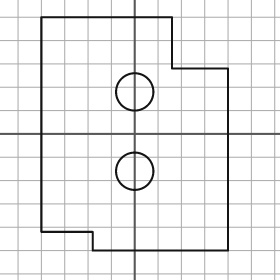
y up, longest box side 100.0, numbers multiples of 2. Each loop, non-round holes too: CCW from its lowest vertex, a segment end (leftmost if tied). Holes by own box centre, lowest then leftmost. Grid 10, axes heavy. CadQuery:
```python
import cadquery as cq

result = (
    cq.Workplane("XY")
    .moveTo(-18.0, -50.0)
    .lineTo(40.0, -50.0)
    .lineTo(40.0, 28.0)
    .lineTo(16.0, 28.0)
    .lineTo(16.0, 50.0)
    .lineTo(-40.0, 50.0)
    .lineTo(-40.0, -42.0)
    .lineTo(-18.0, -42.0)
    .close()
    .moveTo(0.0, -16.0)
    .circle(8.0)
    .moveTo(0.0, 18.0)
    .circle(8.0)
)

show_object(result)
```